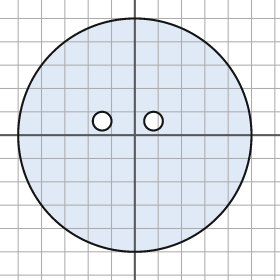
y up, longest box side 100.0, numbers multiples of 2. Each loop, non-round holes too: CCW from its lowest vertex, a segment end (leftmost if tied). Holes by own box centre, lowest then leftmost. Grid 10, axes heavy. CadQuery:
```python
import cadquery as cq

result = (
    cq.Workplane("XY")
    .moveTo(0.0, 0.0)
    .circle(50.0)
    .moveTo(-14.0, 6.0)
    .circle(4.0)
    .moveTo(8.0, 6.0)
    .circle(4.0)
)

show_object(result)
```